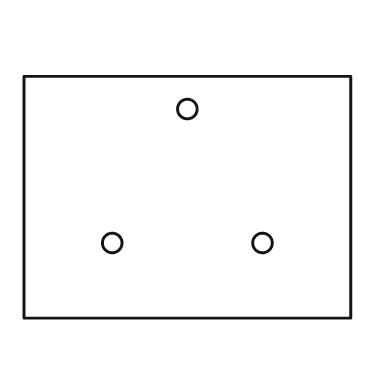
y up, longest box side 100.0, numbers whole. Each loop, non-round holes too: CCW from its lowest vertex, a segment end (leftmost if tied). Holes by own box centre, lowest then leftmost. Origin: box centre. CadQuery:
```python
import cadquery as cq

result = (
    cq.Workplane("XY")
    .moveTo(-50.0, -37.0)
    .lineTo(50.0, -37.0)
    .lineTo(50.0, 37.0)
    .lineTo(-50.0, 37.0)
    .close()
    .moveTo(-23.0, -14.0)
    .circle(3.0)
    .moveTo(23.0, -14.0)
    .circle(3.0)
    .moveTo(0.0, 27.0)
    .circle(3.0)
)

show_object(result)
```